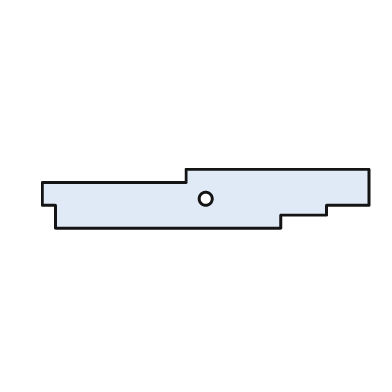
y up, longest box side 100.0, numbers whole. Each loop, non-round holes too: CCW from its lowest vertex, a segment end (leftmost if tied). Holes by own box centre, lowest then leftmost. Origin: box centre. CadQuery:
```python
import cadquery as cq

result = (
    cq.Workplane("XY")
    .moveTo(-46.0, -9.0)
    .lineTo(23.0, -9.0)
    .lineTo(23.0, -5.0)
    .lineTo(37.0, -5.0)
    .lineTo(37.0, -2.0)
    .lineTo(50.0, -2.0)
    .lineTo(50.0, 9.0)
    .lineTo(-6.0, 9.0)
    .lineTo(-6.0, 5.0)
    .lineTo(-50.0, 5.0)
    .lineTo(-50.0, -2.0)
    .lineTo(-46.0, -2.0)
    .close()
    .moveTo(0.0, 0.0)
    .circle(2.0)
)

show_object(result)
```